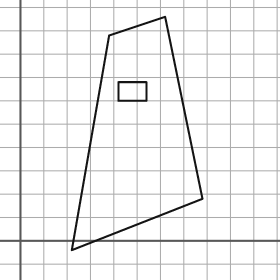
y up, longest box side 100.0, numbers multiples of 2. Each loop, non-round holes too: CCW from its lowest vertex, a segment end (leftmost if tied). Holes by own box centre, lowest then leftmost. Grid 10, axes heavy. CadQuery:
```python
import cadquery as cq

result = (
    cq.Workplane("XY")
    .moveTo(22.0, -4.0)
    .lineTo(78.0, 18.0)
    .lineTo(62.0, 96.0)
    .lineTo(38.0, 88.0)
    .close()
    .moveTo(42.0, 60.0)
    .lineTo(54.0, 60.0)
    .lineTo(54.0, 68.0)
    .lineTo(42.0, 68.0)
    .close()
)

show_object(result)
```